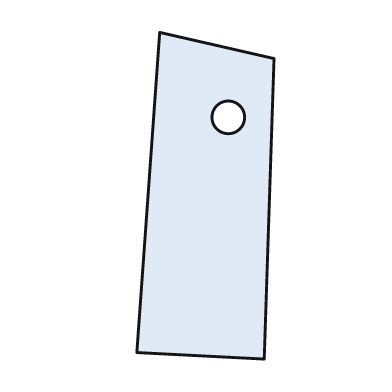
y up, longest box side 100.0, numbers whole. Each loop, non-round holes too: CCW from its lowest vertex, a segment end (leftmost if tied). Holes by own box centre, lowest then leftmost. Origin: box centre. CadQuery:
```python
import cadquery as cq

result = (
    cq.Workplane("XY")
    .moveTo(18.0, -50.0)
    .lineTo(21.0, 42.0)
    .lineTo(-14.0, 50.0)
    .lineTo(-21.0, -48.0)
    .close()
    .moveTo(7.0, 24.0)
    .circle(5.0)
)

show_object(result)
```